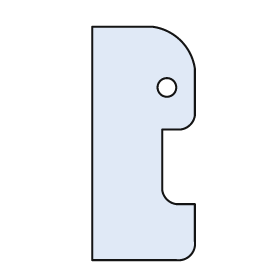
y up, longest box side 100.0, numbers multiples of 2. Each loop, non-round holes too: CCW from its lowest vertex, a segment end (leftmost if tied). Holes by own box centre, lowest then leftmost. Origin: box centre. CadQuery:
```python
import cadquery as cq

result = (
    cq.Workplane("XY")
    .moveTo(-22.0, -50.0)
    .lineTo(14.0, -50.0)
    .threePointArc((20.0, -48.0), (22.0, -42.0))
    .lineTo(22.0, -26.0)
    .lineTo(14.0, -26.0)
    .threePointArc((10.0, -24.0), (8.0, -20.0))
    .lineTo(8.0, 6.0)
    .lineTo(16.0, 6.0)
    .threePointArc((20.0, 8.0), (22.0, 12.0))
    .lineTo(22.0, 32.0)
    .threePointArc((16.0, 44.0), (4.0, 50.0))
    .lineTo(-22.0, 50.0)
    .close()
    .moveTo(10.0, 24.0)
    .circle(4.0)
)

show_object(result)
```